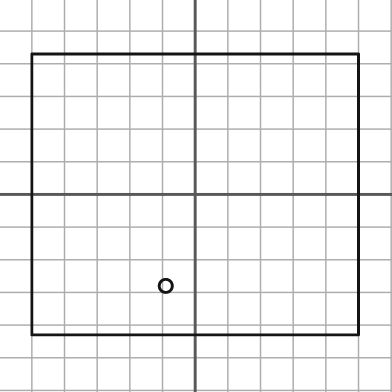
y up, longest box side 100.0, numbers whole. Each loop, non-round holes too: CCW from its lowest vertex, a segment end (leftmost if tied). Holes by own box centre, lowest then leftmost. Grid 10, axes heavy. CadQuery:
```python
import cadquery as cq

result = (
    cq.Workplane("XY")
    .moveTo(-50.0, -43.0)
    .lineTo(50.0, -43.0)
    .lineTo(50.0, 43.0)
    .lineTo(-50.0, 43.0)
    .close()
    .moveTo(-9.0, -28.0)
    .circle(2.0)
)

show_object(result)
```